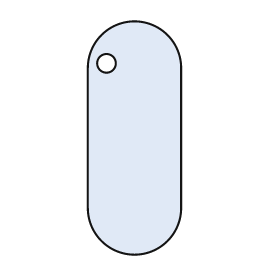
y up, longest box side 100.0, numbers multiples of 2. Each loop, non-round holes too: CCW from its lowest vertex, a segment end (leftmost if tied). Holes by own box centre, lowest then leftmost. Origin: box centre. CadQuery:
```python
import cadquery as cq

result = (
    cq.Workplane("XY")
    .moveTo(-20.0, -30.0)
    .threePointArc((0.0, -50.0), (20.0, -30.0))
    .lineTo(20.0, 30.0)
    .threePointArc((0.0, 50.0), (-20.0, 30.0))
    .close()
    .moveTo(-12.0, 32.0)
    .circle(4.0)
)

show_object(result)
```